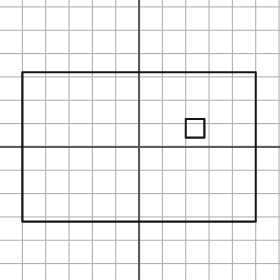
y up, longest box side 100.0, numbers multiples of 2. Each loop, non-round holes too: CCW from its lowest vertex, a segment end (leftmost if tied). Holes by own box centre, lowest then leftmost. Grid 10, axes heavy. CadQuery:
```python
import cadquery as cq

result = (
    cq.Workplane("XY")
    .moveTo(-50.0, -32.0)
    .lineTo(50.0, -32.0)
    .lineTo(50.0, 32.0)
    .lineTo(-50.0, 32.0)
    .close()
    .moveTo(20.0, 4.0)
    .lineTo(28.0, 4.0)
    .lineTo(28.0, 12.0)
    .lineTo(20.0, 12.0)
    .close()
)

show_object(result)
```